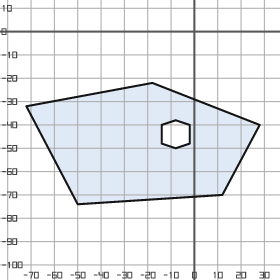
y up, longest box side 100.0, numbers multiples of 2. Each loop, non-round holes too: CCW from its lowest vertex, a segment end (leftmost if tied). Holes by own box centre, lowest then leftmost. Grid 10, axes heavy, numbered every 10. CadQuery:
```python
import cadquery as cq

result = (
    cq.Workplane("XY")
    .moveTo(-50.0, -74.0)
    .lineTo(12.0, -70.0)
    .lineTo(28.0, -40.0)
    .lineTo(-18.0, -22.0)
    .lineTo(-72.0, -32.0)
    .close()
    .moveTo(-8.0, -50.0)
    .lineTo(-2.0, -48.0)
    .lineTo(-2.0, -40.0)
    .lineTo(-8.0, -38.0)
    .lineTo(-14.0, -40.0)
    .lineTo(-14.0, -48.0)
    .close()
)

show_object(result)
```